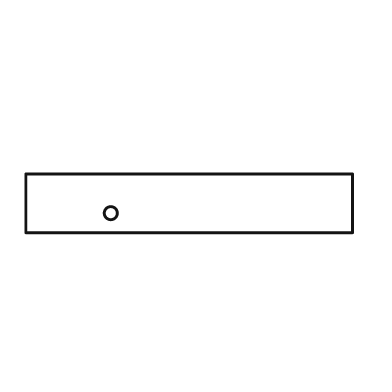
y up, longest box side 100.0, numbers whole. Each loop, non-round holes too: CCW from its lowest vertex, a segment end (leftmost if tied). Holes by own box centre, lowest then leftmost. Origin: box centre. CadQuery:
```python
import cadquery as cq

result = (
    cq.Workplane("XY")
    .moveTo(-50.0, -9.0)
    .lineTo(50.0, -9.0)
    .lineTo(50.0, 9.0)
    .lineTo(-50.0, 9.0)
    .close()
    .moveTo(-24.0, -3.0)
    .circle(2.0)
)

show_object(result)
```